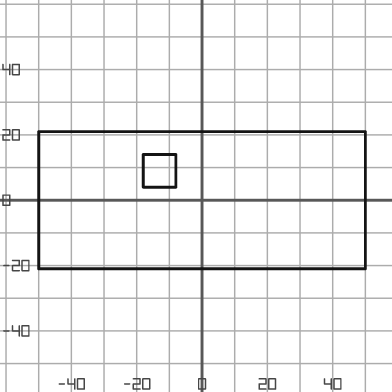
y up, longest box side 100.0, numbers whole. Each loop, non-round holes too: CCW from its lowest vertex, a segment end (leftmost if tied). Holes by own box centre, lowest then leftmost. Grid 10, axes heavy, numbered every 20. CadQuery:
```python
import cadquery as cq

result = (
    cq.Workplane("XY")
    .moveTo(-50.0, -21.0)
    .lineTo(50.0, -21.0)
    .lineTo(50.0, 21.0)
    .lineTo(-50.0, 21.0)
    .close()
    .moveTo(-18.0, 4.0)
    .lineTo(-8.0, 4.0)
    .lineTo(-8.0, 14.0)
    .lineTo(-18.0, 14.0)
    .close()
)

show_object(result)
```